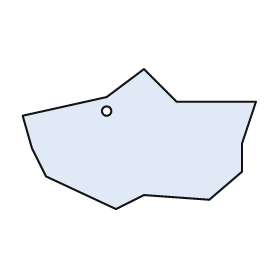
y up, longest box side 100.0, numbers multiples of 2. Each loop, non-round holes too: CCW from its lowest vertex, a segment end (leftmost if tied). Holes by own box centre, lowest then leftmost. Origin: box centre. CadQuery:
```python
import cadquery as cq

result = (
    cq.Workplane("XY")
    .moveTo(-10.0, -30.0)
    .lineTo(2.0, -24.0)
    .lineTo(30.0, -26.0)
    .lineTo(44.0, -14.0)
    .lineTo(44.0, -2.0)
    .lineTo(50.0, 16.0)
    .lineTo(16.0, 16.0)
    .lineTo(2.0, 30.0)
    .lineTo(-14.0, 18.0)
    .lineTo(-50.0, 10.0)
    .lineTo(-46.0, -4.0)
    .lineTo(-40.0, -16.0)
    .close()
    .moveTo(-14.0, 12.0)
    .circle(2.0)
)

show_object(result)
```